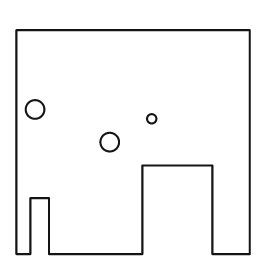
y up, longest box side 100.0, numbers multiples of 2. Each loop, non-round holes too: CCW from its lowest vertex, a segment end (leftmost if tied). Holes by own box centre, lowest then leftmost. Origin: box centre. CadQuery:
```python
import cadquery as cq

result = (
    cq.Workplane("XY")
    .moveTo(-50.0, -48.0)
    .lineTo(-44.0, -48.0)
    .lineTo(-44.0, -24.0)
    .lineTo(-36.0, -24.0)
    .lineTo(-36.0, -48.0)
    .lineTo(4.0, -48.0)
    .lineTo(4.0, -10.0)
    .lineTo(34.0, -10.0)
    .lineTo(34.0, -48.0)
    .lineTo(50.0, -48.0)
    .lineTo(50.0, 48.0)
    .lineTo(-50.0, 48.0)
    .close()
    .moveTo(-10.0, 0.0)
    .circle(4.0)
    .moveTo(8.0, 10.0)
    .circle(2.0)
    .moveTo(-42.0, 14.0)
    .circle(4.0)
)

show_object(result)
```